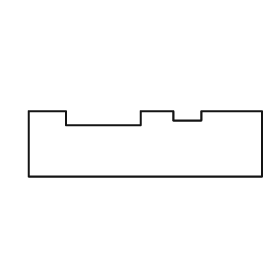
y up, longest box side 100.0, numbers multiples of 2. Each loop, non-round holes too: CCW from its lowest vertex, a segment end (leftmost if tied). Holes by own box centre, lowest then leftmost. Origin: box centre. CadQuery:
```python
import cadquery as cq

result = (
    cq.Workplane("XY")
    .moveTo(-50.0, -14.0)
    .lineTo(50.0, -14.0)
    .lineTo(50.0, 14.0)
    .lineTo(24.0, 14.0)
    .lineTo(24.0, 10.0)
    .lineTo(12.0, 10.0)
    .lineTo(12.0, 14.0)
    .lineTo(-2.0, 14.0)
    .lineTo(-2.0, 8.0)
    .lineTo(-34.0, 8.0)
    .lineTo(-34.0, 14.0)
    .lineTo(-50.0, 14.0)
    .close()
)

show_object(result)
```